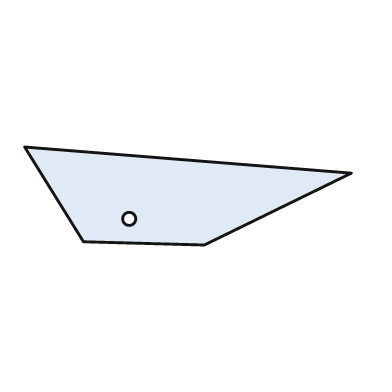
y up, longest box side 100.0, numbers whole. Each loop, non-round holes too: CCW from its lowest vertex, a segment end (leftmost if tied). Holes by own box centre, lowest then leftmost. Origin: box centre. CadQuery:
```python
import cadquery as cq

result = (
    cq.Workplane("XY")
    .moveTo(5.0, -15.0)
    .lineTo(50.0, 7.0)
    .lineTo(-50.0, 15.0)
    .lineTo(-32.0, -14.0)
    .close()
    .moveTo(-18.0, -7.0)
    .circle(2.0)
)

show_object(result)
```